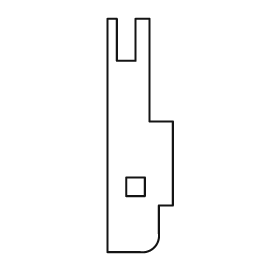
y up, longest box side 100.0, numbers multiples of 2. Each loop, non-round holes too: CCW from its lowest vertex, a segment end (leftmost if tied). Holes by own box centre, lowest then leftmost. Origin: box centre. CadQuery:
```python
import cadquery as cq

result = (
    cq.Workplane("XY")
    .moveTo(-14.0, -50.0)
    .lineTo(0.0, -50.0)
    .threePointArc((6.0, -48.0), (8.0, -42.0))
    .lineTo(8.0, -30.0)
    .lineTo(14.0, -30.0)
    .lineTo(14.0, 6.0)
    .lineTo(4.0, 6.0)
    .lineTo(4.0, 50.0)
    .lineTo(-2.0, 50.0)
    .lineTo(-2.0, 32.0)
    .lineTo(-10.0, 32.0)
    .lineTo(-10.0, 50.0)
    .lineTo(-14.0, 50.0)
    .close()
    .moveTo(-6.0, -26.0)
    .lineTo(2.0, -26.0)
    .lineTo(2.0, -18.0)
    .lineTo(-6.0, -18.0)
    .close()
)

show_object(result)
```